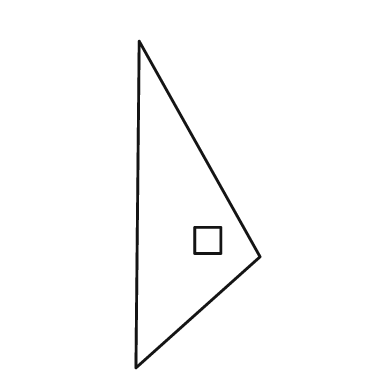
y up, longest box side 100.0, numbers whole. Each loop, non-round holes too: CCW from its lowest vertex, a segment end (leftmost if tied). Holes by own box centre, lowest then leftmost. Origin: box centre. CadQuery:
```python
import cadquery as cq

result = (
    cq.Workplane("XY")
    .moveTo(-19.0, -50.0)
    .lineTo(19.0, -16.0)
    .lineTo(-18.0, 50.0)
    .close()
    .moveTo(-1.0, -15.0)
    .lineTo(7.0, -15.0)
    .lineTo(7.0, -7.0)
    .lineTo(-1.0, -7.0)
    .close()
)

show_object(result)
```